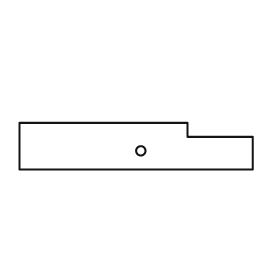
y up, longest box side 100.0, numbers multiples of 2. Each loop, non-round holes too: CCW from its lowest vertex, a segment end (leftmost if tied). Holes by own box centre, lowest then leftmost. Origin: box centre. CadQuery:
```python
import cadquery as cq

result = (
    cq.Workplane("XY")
    .moveTo(-50.0, -10.0)
    .lineTo(50.0, -10.0)
    .lineTo(50.0, 4.0)
    .lineTo(22.0, 4.0)
    .lineTo(22.0, 10.0)
    .lineTo(-50.0, 10.0)
    .close()
    .moveTo(2.0, -2.0)
    .circle(2.0)
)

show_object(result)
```